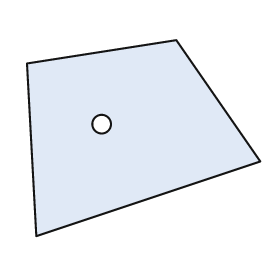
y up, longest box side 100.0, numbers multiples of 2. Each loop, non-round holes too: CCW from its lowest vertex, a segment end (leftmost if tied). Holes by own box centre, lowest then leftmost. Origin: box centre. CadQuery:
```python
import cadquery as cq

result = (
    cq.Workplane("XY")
    .moveTo(-46.0, -42.0)
    .lineTo(50.0, -10.0)
    .lineTo(14.0, 42.0)
    .lineTo(-50.0, 32.0)
    .close()
    .moveTo(-18.0, 6.0)
    .circle(4.0)
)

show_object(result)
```